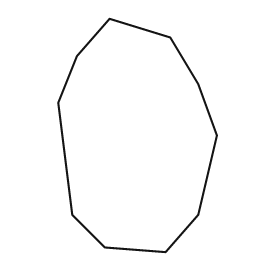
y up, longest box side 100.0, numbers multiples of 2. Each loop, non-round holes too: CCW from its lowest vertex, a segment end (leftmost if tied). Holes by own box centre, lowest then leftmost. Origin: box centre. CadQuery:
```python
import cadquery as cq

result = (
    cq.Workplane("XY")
    .moveTo(12.0, -50.0)
    .lineTo(26.0, -34.0)
    .lineTo(34.0, 0.0)
    .lineTo(26.0, 22.0)
    .lineTo(14.0, 42.0)
    .lineTo(-12.0, 50.0)
    .lineTo(-26.0, 34.0)
    .lineTo(-34.0, 14.0)
    .lineTo(-28.0, -34.0)
    .lineTo(-14.0, -48.0)
    .close()
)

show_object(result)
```